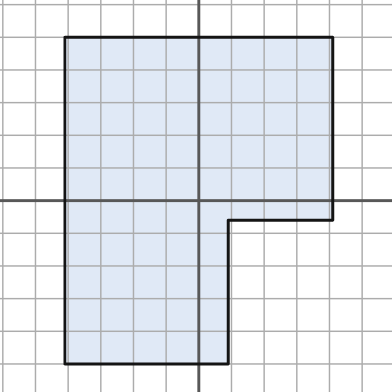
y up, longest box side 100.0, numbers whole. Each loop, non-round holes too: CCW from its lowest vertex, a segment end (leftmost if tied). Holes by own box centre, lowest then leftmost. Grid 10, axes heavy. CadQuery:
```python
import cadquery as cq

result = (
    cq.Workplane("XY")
    .moveTo(-41.0, -50.0)
    .lineTo(9.0, -50.0)
    .lineTo(9.0, -6.0)
    .lineTo(41.0, -6.0)
    .lineTo(41.0, 50.0)
    .lineTo(-41.0, 50.0)
    .close()
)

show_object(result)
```